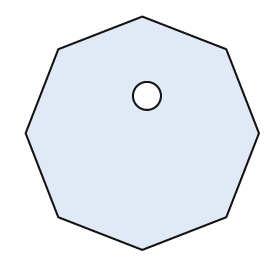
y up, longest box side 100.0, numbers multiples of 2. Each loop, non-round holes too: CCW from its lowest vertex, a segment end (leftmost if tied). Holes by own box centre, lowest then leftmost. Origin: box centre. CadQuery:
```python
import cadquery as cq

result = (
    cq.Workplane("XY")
    .moveTo(0.0, -50.0)
    .lineTo(36.0, -36.0)
    .lineTo(50.0, 0.0)
    .lineTo(36.0, 36.0)
    .lineTo(0.0, 50.0)
    .lineTo(-36.0, 36.0)
    .lineTo(-50.0, 0.0)
    .lineTo(-36.0, -36.0)
    .close()
    .moveTo(2.0, 16.0)
    .circle(6.0)
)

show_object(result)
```